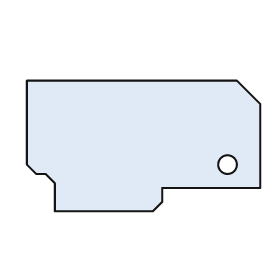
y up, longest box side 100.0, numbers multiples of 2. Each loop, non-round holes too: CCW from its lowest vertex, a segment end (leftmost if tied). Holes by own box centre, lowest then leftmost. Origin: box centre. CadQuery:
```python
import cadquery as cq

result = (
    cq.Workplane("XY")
    .moveTo(-38.0, -28.0)
    .lineTo(4.0, -28.0)
    .lineTo(8.0, -24.0)
    .lineTo(8.0, -18.0)
    .lineTo(50.0, -18.0)
    .lineTo(50.0, 18.0)
    .lineTo(40.0, 28.0)
    .lineTo(-50.0, 28.0)
    .lineTo(-50.0, -8.0)
    .lineTo(-46.0, -12.0)
    .lineTo(-42.0, -12.0)
    .lineTo(-38.0, -16.0)
    .close()
    .moveTo(36.0, -8.0)
    .circle(4.0)
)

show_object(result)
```